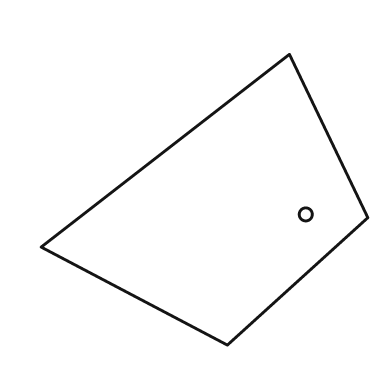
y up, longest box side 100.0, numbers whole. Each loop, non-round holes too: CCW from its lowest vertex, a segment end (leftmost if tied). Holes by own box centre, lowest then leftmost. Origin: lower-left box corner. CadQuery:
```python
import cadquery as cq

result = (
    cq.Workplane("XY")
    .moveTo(57.0, 0.0)
    .lineTo(100.0, 39.0)
    .lineTo(76.0, 89.0)
    .lineTo(0.0, 30.0)
    .close()
    .moveTo(81.0, 40.0)
    .circle(2.0)
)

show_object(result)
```